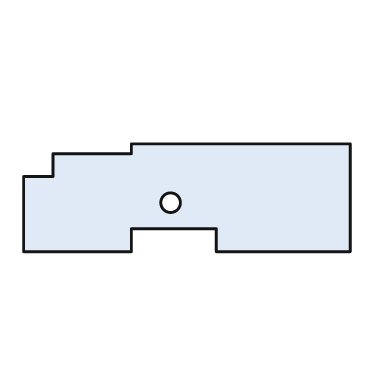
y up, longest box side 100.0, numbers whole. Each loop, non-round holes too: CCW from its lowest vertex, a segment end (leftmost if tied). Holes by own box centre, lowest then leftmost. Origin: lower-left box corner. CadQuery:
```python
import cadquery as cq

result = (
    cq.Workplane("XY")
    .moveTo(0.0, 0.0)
    .lineTo(33.0, 0.0)
    .lineTo(33.0, 7.0)
    .lineTo(59.0, 7.0)
    .lineTo(59.0, 0.0)
    .lineTo(100.0, 0.0)
    .lineTo(100.0, 33.0)
    .lineTo(33.0, 33.0)
    .lineTo(33.0, 30.0)
    .lineTo(9.0, 30.0)
    .lineTo(9.0, 23.0)
    .lineTo(0.0, 23.0)
    .close()
    .moveTo(45.0, 15.0)
    .circle(3.0)
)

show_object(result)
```